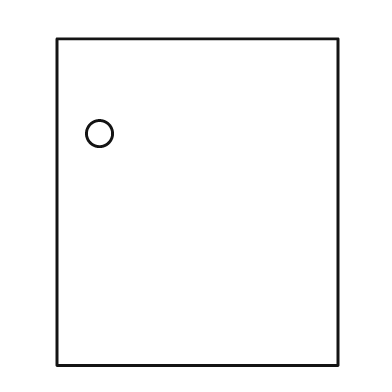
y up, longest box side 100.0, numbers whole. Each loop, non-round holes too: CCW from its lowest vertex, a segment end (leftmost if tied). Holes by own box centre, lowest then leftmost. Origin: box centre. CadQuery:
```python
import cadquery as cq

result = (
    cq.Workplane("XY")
    .moveTo(-43.0, -50.0)
    .lineTo(43.0, -50.0)
    .lineTo(43.0, 50.0)
    .lineTo(-43.0, 50.0)
    .close()
    .moveTo(-30.0, 21.0)
    .circle(4.0)
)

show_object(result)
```